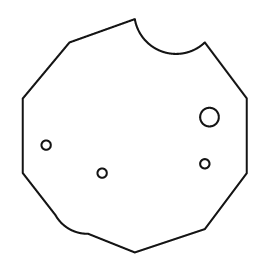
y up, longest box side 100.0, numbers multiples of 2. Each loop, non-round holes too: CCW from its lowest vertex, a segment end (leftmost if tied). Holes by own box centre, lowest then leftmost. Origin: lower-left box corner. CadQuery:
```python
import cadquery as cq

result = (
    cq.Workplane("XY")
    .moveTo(48.0, 0.0)
    .lineTo(78.0, 10.0)
    .lineTo(96.0, 34.0)
    .lineTo(96.0, 66.0)
    .lineTo(78.0, 90.0)
    .threePointArc((60.0, 86.0), (48.0, 100.0))
    .lineTo(20.0, 90.0)
    .lineTo(0.0, 66.0)
    .lineTo(0.0, 34.0)
    .lineTo(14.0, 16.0)
    .threePointArc((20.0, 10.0), (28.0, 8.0))
    .close()
    .moveTo(34.0, 34.0)
    .circle(2.0)
    .moveTo(78.0, 38.0)
    .circle(2.0)
    .moveTo(10.0, 46.0)
    .circle(2.0)
    .moveTo(80.0, 58.0)
    .circle(4.0)
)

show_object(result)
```